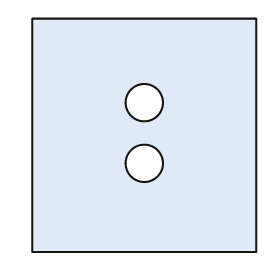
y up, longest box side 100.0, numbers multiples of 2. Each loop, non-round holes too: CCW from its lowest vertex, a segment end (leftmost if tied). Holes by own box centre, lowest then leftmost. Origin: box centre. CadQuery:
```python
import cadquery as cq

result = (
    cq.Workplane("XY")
    .moveTo(-48.0, -50.0)
    .lineTo(48.0, -50.0)
    .lineTo(48.0, 50.0)
    .lineTo(-48.0, 50.0)
    .close()
    .moveTo(0.0, -12.0)
    .circle(8.0)
    .moveTo(0.0, 14.0)
    .circle(8.0)
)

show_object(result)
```